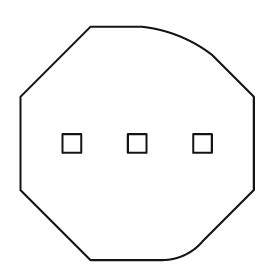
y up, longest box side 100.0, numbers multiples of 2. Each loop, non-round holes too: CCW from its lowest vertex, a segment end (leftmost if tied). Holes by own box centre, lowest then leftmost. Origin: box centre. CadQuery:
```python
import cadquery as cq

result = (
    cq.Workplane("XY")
    .moveTo(-20.0, -50.0)
    .lineTo(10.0, -50.0)
    .threePointArc((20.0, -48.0), (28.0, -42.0))
    .lineTo(50.0, -20.0)
    .lineTo(50.0, 20.0)
    .lineTo(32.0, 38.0)
    .threePointArc((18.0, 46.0), (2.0, 50.0))
    .lineTo(-20.0, 50.0)
    .lineTo(-50.0, 20.0)
    .lineTo(-50.0, -20.0)
    .close()
    .moveTo(-32.0, -4.0)
    .lineTo(-24.0, -4.0)
    .lineTo(-24.0, 4.0)
    .lineTo(-32.0, 4.0)
    .close()
    .moveTo(-4.0, -4.0)
    .lineTo(4.0, -4.0)
    .lineTo(4.0, 4.0)
    .lineTo(-4.0, 4.0)
    .close()
    .moveTo(24.0, -4.0)
    .lineTo(32.0, -4.0)
    .lineTo(32.0, 4.0)
    .lineTo(24.0, 4.0)
    .close()
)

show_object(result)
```